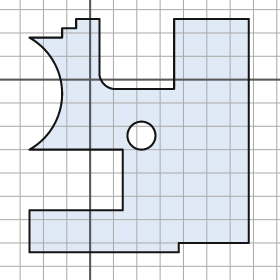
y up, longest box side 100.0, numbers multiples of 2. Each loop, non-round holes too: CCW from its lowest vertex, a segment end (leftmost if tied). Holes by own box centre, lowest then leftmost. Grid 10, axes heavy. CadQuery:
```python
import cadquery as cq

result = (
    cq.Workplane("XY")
    .moveTo(-26.0, -74.0)
    .lineTo(38.0, -74.0)
    .lineTo(38.0, -70.0)
    .lineTo(68.0, -70.0)
    .lineTo(68.0, 26.0)
    .lineTo(36.0, 26.0)
    .lineTo(36.0, -4.0)
    .lineTo(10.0, -4.0)
    .threePointArc((6.0, -2.0), (4.0, 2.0))
    .lineTo(4.0, 26.0)
    .lineTo(-6.0, 26.0)
    .lineTo(-6.0, 22.0)
    .lineTo(-12.0, 22.0)
    .lineTo(-12.0, 18.0)
    .lineTo(-26.0, 18.0)
    .threePointArc((-12.0, -6.0), (-26.0, -30.0))
    .lineTo(14.0, -30.0)
    .lineTo(14.0, -56.0)
    .lineTo(-26.0, -56.0)
    .close()
    .moveTo(22.0, -24.0)
    .circle(6.0)
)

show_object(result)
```